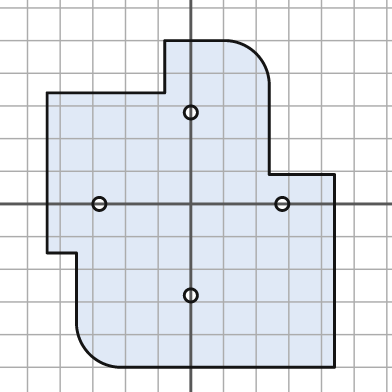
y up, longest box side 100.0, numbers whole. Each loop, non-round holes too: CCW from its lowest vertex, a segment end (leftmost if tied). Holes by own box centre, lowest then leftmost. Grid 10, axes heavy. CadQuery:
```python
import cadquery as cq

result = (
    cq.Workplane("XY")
    .moveTo(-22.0, -50.0)
    .lineTo(44.0, -50.0)
    .lineTo(44.0, 9.0)
    .lineTo(24.0, 9.0)
    .lineTo(24.0, 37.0)
    .threePointArc((20.0, 46.0), (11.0, 50.0))
    .lineTo(-8.0, 50.0)
    .lineTo(-8.0, 34.0)
    .lineTo(-44.0, 34.0)
    .lineTo(-44.0, -15.0)
    .lineTo(-35.0, -15.0)
    .lineTo(-35.0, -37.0)
    .threePointArc((-31.0, -46.0), (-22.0, -50.0))
    .close()
    .moveTo(0.0, -28.0)
    .circle(2.0)
    .moveTo(-28.0, 0.0)
    .circle(2.0)
    .moveTo(28.0, 0.0)
    .circle(2.0)
    .moveTo(0.0, 28.0)
    .circle(2.0)
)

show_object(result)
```